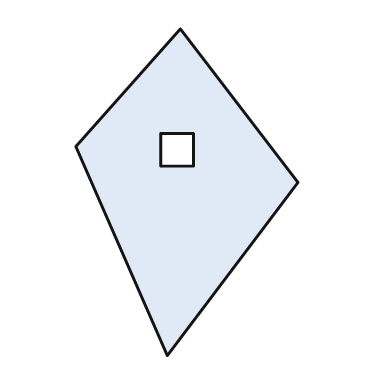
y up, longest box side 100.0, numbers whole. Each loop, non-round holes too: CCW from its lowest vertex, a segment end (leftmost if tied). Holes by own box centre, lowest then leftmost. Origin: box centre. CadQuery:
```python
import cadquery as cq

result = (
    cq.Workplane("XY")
    .moveTo(-6.0, -50.0)
    .lineTo(34.0, 3.0)
    .lineTo(-2.0, 50.0)
    .lineTo(-34.0, 14.0)
    .close()
    .moveTo(-8.0, 8.0)
    .lineTo(2.0, 8.0)
    .lineTo(2.0, 18.0)
    .lineTo(-8.0, 18.0)
    .close()
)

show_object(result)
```